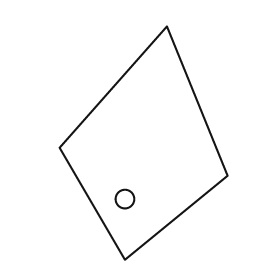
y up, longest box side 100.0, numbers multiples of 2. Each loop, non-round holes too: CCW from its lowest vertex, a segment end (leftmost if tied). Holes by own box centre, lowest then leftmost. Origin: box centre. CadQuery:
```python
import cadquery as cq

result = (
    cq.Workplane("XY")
    .moveTo(-8.0, -50.0)
    .lineTo(36.0, -14.0)
    .lineTo(10.0, 50.0)
    .lineTo(-36.0, -2.0)
    .close()
    .moveTo(-8.0, -24.0)
    .circle(4.0)
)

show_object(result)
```